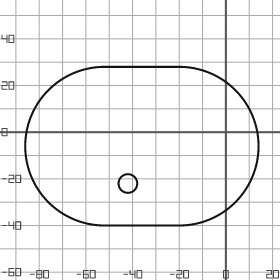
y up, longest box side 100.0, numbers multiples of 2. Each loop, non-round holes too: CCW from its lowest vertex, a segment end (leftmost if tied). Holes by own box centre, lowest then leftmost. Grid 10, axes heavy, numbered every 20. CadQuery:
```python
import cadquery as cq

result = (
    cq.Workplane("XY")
    .moveTo(-52.0, -40.0)
    .lineTo(-20.0, -40.0)
    .threePointArc((14.0, -6.0), (-20.0, 28.0))
    .lineTo(-52.0, 28.0)
    .threePointArc((-86.0, -6.0), (-52.0, -40.0))
    .close()
    .moveTo(-42.0, -22.0)
    .circle(4.0)
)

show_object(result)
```